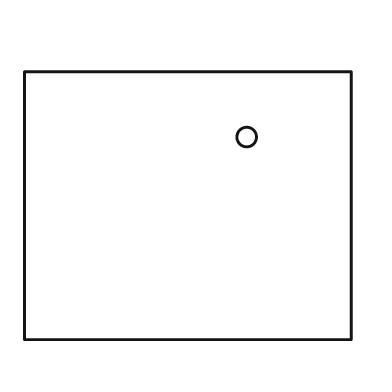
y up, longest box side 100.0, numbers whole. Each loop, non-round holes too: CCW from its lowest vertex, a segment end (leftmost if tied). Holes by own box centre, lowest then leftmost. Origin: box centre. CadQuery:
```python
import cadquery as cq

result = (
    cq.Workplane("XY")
    .moveTo(-50.0, -41.0)
    .lineTo(50.0, -41.0)
    .lineTo(50.0, 41.0)
    .lineTo(-50.0, 41.0)
    .close()
    .moveTo(18.0, 21.0)
    .circle(3.0)
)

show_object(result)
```